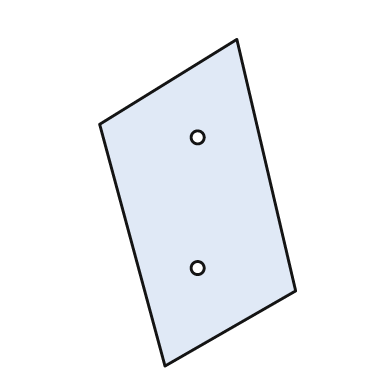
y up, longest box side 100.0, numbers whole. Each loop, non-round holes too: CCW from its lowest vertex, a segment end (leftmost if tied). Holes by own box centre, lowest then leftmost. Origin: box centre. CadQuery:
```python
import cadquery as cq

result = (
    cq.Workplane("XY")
    .moveTo(-10.0, -50.0)
    .lineTo(30.0, -27.0)
    .lineTo(12.0, 50.0)
    .lineTo(-30.0, 24.0)
    .close()
    .moveTo(0.0, -20.0)
    .circle(2.0)
    .moveTo(0.0, 20.0)
    .circle(2.0)
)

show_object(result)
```